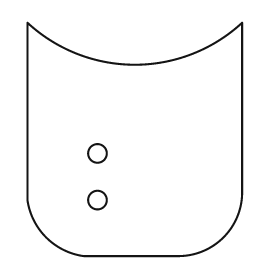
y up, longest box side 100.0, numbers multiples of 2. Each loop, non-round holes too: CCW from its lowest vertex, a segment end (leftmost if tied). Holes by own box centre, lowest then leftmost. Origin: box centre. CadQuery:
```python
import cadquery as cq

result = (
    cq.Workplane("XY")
    .moveTo(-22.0, -50.0)
    .lineTo(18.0, -50.0)
    .threePointArc((38.0, -42.0), (46.0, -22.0))
    .lineTo(46.0, 50.0)
    .threePointArc((0.0, 32.0), (-46.0, 50.0))
    .lineTo(-46.0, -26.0)
    .threePointArc((-38.0, -42.0), (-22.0, -50.0))
    .close()
    .moveTo(-16.0, -26.0)
    .circle(4.0)
    .moveTo(-16.0, -6.0)
    .circle(4.0)
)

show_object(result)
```